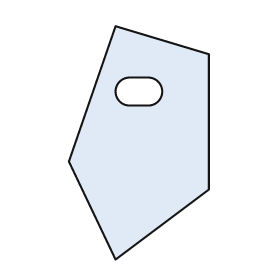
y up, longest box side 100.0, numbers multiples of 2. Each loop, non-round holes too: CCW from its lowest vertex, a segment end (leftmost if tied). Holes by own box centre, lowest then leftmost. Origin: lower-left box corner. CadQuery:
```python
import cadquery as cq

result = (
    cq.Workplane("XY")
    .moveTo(20.0, 0.0)
    .lineTo(60.0, 30.0)
    .lineTo(60.0, 88.0)
    .lineTo(20.0, 100.0)
    .lineTo(0.0, 42.0)
    .close()
    .moveTo(26.0, 66.0)
    .lineTo(34.0, 66.0)
    .threePointArc((40.0, 72.0), (34.0, 78.0))
    .lineTo(26.0, 78.0)
    .threePointArc((20.0, 72.0), (26.0, 66.0))
    .close()
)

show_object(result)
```